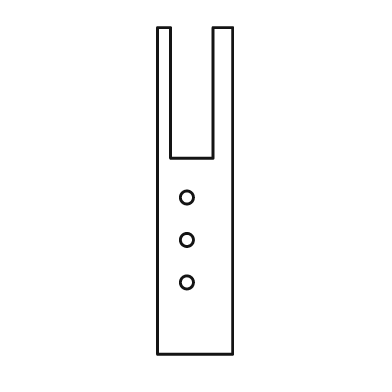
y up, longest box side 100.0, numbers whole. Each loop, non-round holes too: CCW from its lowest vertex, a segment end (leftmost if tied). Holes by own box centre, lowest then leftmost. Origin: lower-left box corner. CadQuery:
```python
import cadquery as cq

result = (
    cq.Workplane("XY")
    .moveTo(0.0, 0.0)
    .lineTo(23.0, 0.0)
    .lineTo(23.0, 100.0)
    .lineTo(17.0, 100.0)
    .lineTo(17.0, 60.0)
    .lineTo(4.0, 60.0)
    .lineTo(4.0, 100.0)
    .lineTo(0.0, 100.0)
    .close()
    .moveTo(9.0, 22.0)
    .circle(2.0)
    .moveTo(9.0, 35.0)
    .circle(2.0)
    .moveTo(9.0, 48.0)
    .circle(2.0)
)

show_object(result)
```